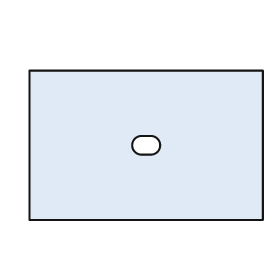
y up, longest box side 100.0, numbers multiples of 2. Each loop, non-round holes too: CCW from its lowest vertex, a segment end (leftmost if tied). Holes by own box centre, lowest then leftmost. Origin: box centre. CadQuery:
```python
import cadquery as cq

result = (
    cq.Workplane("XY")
    .moveTo(-50.0, -32.0)
    .lineTo(50.0, -32.0)
    .lineTo(50.0, 32.0)
    .lineTo(-50.0, 32.0)
    .close()
    .moveTo(-2.0, -4.0)
    .lineTo(2.0, -4.0)
    .threePointArc((6.0, 0.0), (2.0, 4.0))
    .lineTo(-2.0, 4.0)
    .threePointArc((-6.0, 0.0), (-2.0, -4.0))
    .close()
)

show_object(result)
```